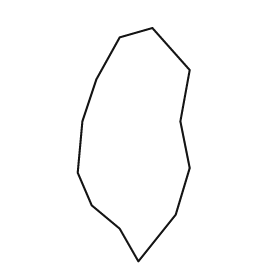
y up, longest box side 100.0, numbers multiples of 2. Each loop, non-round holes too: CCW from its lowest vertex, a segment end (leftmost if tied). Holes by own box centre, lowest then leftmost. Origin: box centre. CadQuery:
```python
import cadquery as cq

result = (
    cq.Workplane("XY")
    .moveTo(2.0, -50.0)
    .lineTo(18.0, -30.0)
    .lineTo(24.0, -10.0)
    .lineTo(20.0, 10.0)
    .lineTo(24.0, 32.0)
    .lineTo(8.0, 50.0)
    .lineTo(-6.0, 46.0)
    .lineTo(-16.0, 28.0)
    .lineTo(-22.0, 10.0)
    .lineTo(-24.0, -12.0)
    .lineTo(-18.0, -26.0)
    .lineTo(-6.0, -36.0)
    .close()
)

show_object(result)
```